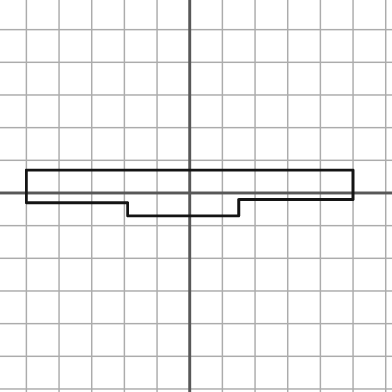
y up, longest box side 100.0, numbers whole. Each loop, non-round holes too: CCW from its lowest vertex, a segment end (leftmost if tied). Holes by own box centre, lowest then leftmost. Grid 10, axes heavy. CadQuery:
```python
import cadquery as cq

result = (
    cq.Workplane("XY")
    .moveTo(-19.0, -7.0)
    .lineTo(15.0, -7.0)
    .lineTo(15.0, -2.0)
    .lineTo(50.0, -2.0)
    .lineTo(50.0, 7.0)
    .lineTo(-50.0, 7.0)
    .lineTo(-50.0, -3.0)
    .lineTo(-19.0, -3.0)
    .close()
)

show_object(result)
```